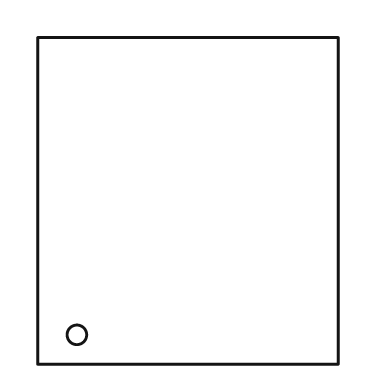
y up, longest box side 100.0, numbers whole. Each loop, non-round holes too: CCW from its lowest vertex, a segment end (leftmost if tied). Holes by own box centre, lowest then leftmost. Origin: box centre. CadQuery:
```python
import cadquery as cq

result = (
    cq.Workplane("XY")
    .moveTo(-46.0, -50.0)
    .lineTo(46.0, -50.0)
    .lineTo(46.0, 50.0)
    .lineTo(-46.0, 50.0)
    .close()
    .moveTo(-34.0, -41.0)
    .circle(3.0)
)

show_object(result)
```